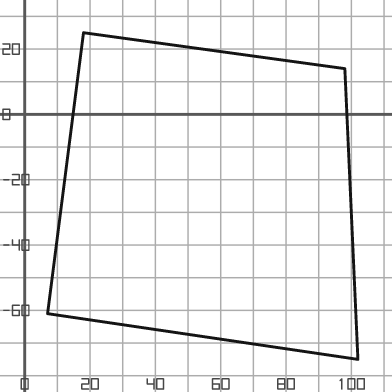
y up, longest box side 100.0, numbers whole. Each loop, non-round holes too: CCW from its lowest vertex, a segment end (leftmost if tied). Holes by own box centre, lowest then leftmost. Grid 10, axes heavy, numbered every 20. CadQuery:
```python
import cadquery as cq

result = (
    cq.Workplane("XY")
    .moveTo(102.0, -75.0)
    .lineTo(98.0, 14.0)
    .lineTo(18.0, 25.0)
    .lineTo(7.0, -61.0)
    .close()
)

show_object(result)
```